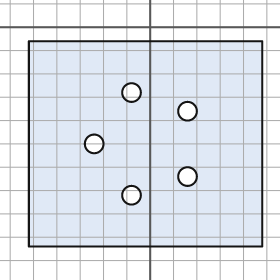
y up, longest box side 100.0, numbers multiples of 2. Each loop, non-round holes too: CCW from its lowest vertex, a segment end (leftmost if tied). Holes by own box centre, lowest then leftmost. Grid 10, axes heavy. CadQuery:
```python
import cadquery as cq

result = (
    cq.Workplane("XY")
    .moveTo(-52.0, -94.0)
    .lineTo(48.0, -94.0)
    .lineTo(48.0, -6.0)
    .lineTo(-52.0, -6.0)
    .close()
    .moveTo(-8.0, -72.0)
    .circle(4.0)
    .moveTo(16.0, -64.0)
    .circle(4.0)
    .moveTo(-24.0, -50.0)
    .circle(4.0)
    .moveTo(16.0, -36.0)
    .circle(4.0)
    .moveTo(-8.0, -28.0)
    .circle(4.0)
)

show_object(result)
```